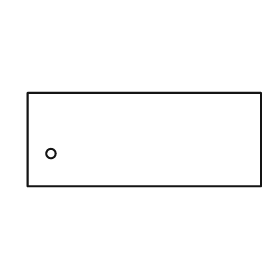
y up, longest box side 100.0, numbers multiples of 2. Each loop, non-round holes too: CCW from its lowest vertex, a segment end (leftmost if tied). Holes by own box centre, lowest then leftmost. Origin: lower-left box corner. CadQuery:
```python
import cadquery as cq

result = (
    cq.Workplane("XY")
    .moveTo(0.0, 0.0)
    .lineTo(100.0, 0.0)
    .lineTo(100.0, 40.0)
    .lineTo(0.0, 40.0)
    .close()
    .moveTo(10.0, 14.0)
    .circle(2.0)
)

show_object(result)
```